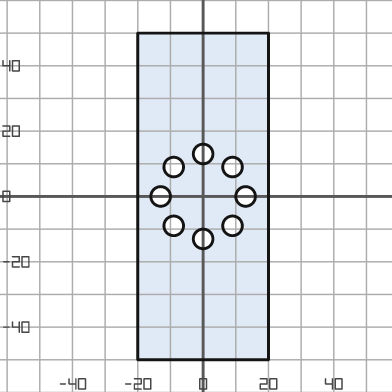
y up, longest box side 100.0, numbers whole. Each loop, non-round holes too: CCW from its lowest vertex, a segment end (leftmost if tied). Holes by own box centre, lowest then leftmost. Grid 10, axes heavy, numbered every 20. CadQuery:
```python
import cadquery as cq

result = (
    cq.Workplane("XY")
    .moveTo(-20.0, -50.0)
    .lineTo(20.0, -50.0)
    .lineTo(20.0, 50.0)
    .lineTo(-20.0, 50.0)
    .close()
    .moveTo(0.0, -13.0)
    .circle(3.0)
    .moveTo(-9.0, -9.0)
    .circle(3.0)
    .moveTo(9.0, -9.0)
    .circle(3.0)
    .moveTo(-13.0, 0.0)
    .circle(3.0)
    .moveTo(13.0, 0.0)
    .circle(3.0)
    .moveTo(-9.0, 9.0)
    .circle(3.0)
    .moveTo(9.0, 9.0)
    .circle(3.0)
    .moveTo(0.0, 13.0)
    .circle(3.0)
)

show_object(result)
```